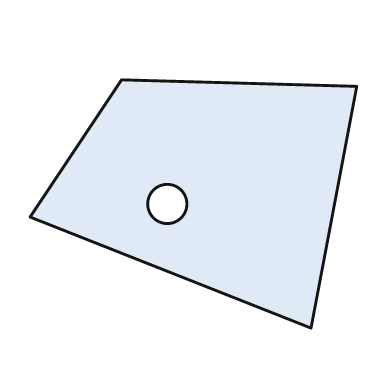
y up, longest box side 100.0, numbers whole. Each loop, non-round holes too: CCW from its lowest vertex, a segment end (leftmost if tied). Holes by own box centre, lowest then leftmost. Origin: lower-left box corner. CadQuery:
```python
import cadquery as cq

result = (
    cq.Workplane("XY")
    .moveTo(86.0, 0.0)
    .lineTo(100.0, 74.0)
    .lineTo(28.0, 76.0)
    .lineTo(0.0, 34.0)
    .close()
    .moveTo(42.0, 38.0)
    .circle(6.0)
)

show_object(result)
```